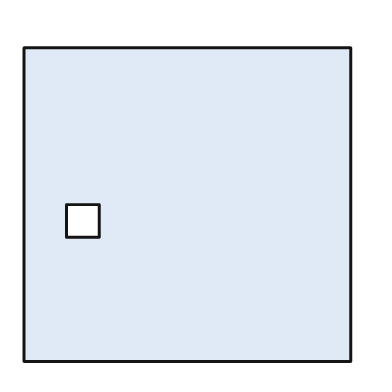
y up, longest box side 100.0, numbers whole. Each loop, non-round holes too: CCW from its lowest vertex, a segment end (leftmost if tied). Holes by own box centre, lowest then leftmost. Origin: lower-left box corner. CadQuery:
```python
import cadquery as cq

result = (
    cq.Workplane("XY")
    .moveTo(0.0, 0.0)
    .lineTo(100.0, 0.0)
    .lineTo(100.0, 96.0)
    .lineTo(0.0, 96.0)
    .close()
    .moveTo(13.0, 38.0)
    .lineTo(23.0, 38.0)
    .lineTo(23.0, 48.0)
    .lineTo(13.0, 48.0)
    .close()
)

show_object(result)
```